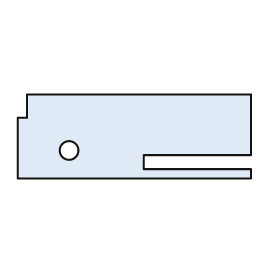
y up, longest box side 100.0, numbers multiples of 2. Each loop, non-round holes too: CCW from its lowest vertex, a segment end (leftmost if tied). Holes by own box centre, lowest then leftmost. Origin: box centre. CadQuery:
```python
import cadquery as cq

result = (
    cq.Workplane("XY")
    .moveTo(-50.0, -18.0)
    .lineTo(50.0, -18.0)
    .lineTo(50.0, -14.0)
    .lineTo(4.0, -14.0)
    .lineTo(4.0, -8.0)
    .lineTo(50.0, -8.0)
    .lineTo(50.0, 18.0)
    .lineTo(-46.0, 18.0)
    .lineTo(-46.0, 8.0)
    .lineTo(-50.0, 8.0)
    .close()
    .moveTo(-28.0, -6.0)
    .circle(4.0)
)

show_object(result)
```